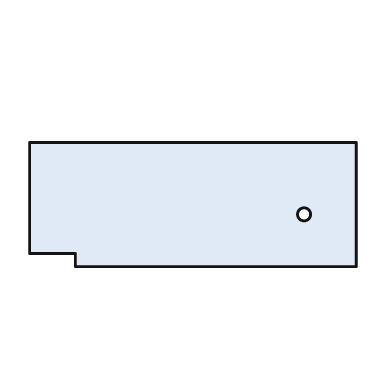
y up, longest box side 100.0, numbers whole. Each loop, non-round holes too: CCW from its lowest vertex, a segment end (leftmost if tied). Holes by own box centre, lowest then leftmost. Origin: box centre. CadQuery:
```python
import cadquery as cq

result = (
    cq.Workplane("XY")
    .moveTo(-36.0, -19.0)
    .lineTo(50.0, -19.0)
    .lineTo(50.0, 19.0)
    .lineTo(-50.0, 19.0)
    .lineTo(-50.0, -15.0)
    .lineTo(-36.0, -15.0)
    .close()
    .moveTo(34.0, -3.0)
    .circle(2.0)
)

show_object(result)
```